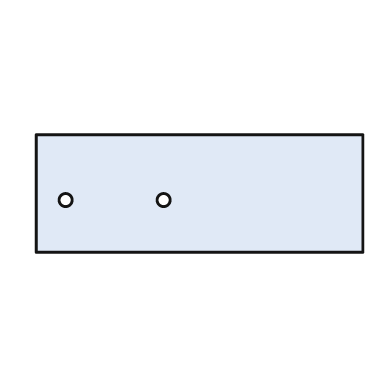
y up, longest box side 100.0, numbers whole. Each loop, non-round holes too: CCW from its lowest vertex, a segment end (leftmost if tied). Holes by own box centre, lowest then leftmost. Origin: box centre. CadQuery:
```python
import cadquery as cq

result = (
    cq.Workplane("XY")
    .moveTo(-50.0, -18.0)
    .lineTo(50.0, -18.0)
    .lineTo(50.0, 18.0)
    .lineTo(-50.0, 18.0)
    .close()
    .moveTo(-41.0, -2.0)
    .circle(2.0)
    .moveTo(-11.0, -2.0)
    .circle(2.0)
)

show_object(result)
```